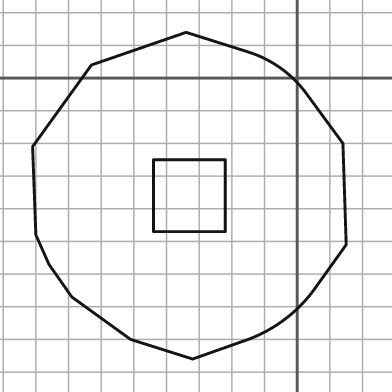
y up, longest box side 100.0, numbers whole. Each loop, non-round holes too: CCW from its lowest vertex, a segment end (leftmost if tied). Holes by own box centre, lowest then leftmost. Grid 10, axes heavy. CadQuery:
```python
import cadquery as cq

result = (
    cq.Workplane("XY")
    .moveTo(-32.0, -86.0)
    .lineTo(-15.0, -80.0)
    .threePointArc((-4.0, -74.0), (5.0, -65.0))
    .lineTo(15.0, -51.0)
    .lineTo(14.0, -20.0)
    .lineTo(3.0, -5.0)
    .threePointArc((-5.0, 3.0), (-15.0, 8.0))
    .lineTo(-34.0, 14.0)
    .lineTo(-63.0, 4.0)
    .lineTo(-81.0, -21.0)
    .lineTo(-80.0, -48.0)
    .lineTo(-76.0, -57.0)
    .lineTo(-69.0, -67.0)
    .lineTo(-51.0, -80.0)
    .close()
    .moveTo(-44.0, -47.0)
    .lineTo(-22.0, -47.0)
    .lineTo(-22.0, -25.0)
    .lineTo(-44.0, -25.0)
    .close()
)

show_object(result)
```